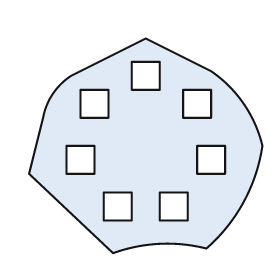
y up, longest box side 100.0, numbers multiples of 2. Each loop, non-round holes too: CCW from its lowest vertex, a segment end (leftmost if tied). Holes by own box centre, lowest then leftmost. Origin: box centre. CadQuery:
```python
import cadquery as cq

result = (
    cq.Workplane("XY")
    .moveTo(-14.0, -46.0)
    .threePointArc((6.0, -42.0), (26.0, -44.0))
    .threePointArc((42.0, -24.0), (50.0, 0.0))
    .threePointArc((42.0, 18.0), (28.0, 32.0))
    .lineTo(0.0, 46.0)
    .lineTo(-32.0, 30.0)
    .threePointArc((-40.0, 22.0), (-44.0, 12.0))
    .lineTo(-50.0, -12.0)
    .close()
    .moveTo(-18.0, -32.0)
    .lineTo(-6.0, -32.0)
    .lineTo(-6.0, -20.0)
    .lineTo(-18.0, -20.0)
    .close()
    .moveTo(6.0, -32.0)
    .lineTo(18.0, -32.0)
    .lineTo(18.0, -20.0)
    .lineTo(6.0, -20.0)
    .close()
    .moveTo(-34.0, -12.0)
    .lineTo(-22.0, -12.0)
    .lineTo(-22.0, 0.0)
    .lineTo(-34.0, 0.0)
    .close()
    .moveTo(22.0, -12.0)
    .lineTo(34.0, -12.0)
    .lineTo(34.0, 0.0)
    .lineTo(22.0, 0.0)
    .close()
    .moveTo(-28.0, 12.0)
    .lineTo(-16.0, 12.0)
    .lineTo(-16.0, 24.0)
    .lineTo(-28.0, 24.0)
    .close()
    .moveTo(16.0, 12.0)
    .lineTo(28.0, 12.0)
    .lineTo(28.0, 24.0)
    .lineTo(16.0, 24.0)
    .close()
    .moveTo(-6.0, 24.0)
    .lineTo(6.0, 24.0)
    .lineTo(6.0, 36.0)
    .lineTo(-6.0, 36.0)
    .close()
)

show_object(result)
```